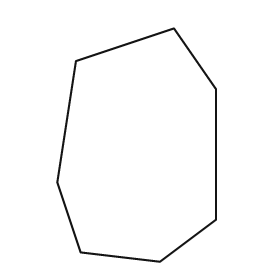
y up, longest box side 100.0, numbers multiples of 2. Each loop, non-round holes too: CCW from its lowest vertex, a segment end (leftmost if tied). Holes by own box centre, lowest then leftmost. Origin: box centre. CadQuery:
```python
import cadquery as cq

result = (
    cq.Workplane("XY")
    .moveTo(10.0, -50.0)
    .lineTo(34.0, -32.0)
    .lineTo(34.0, 24.0)
    .lineTo(16.0, 50.0)
    .lineTo(-26.0, 36.0)
    .lineTo(-34.0, -16.0)
    .lineTo(-24.0, -46.0)
    .close()
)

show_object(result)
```